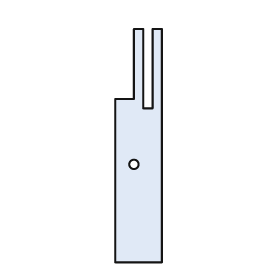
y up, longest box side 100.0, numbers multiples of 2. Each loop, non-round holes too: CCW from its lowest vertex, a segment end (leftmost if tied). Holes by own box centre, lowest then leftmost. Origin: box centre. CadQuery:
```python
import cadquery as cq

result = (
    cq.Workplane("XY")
    .moveTo(-10.0, -50.0)
    .lineTo(10.0, -50.0)
    .lineTo(10.0, 50.0)
    .lineTo(6.0, 50.0)
    .lineTo(6.0, 16.0)
    .lineTo(2.0, 16.0)
    .lineTo(2.0, 50.0)
    .lineTo(-2.0, 50.0)
    .lineTo(-2.0, 20.0)
    .lineTo(-10.0, 20.0)
    .close()
    .moveTo(-2.0, -8.0)
    .circle(2.0)
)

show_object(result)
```